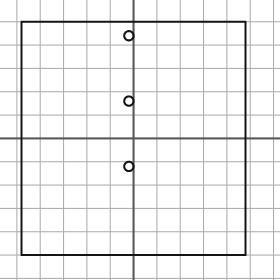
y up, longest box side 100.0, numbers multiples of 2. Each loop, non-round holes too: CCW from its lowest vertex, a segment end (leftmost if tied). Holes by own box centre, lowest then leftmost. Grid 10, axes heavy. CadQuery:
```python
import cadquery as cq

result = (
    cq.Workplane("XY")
    .moveTo(-48.0, -50.0)
    .lineTo(48.0, -50.0)
    .lineTo(48.0, 50.0)
    .lineTo(-48.0, 50.0)
    .close()
    .moveTo(-2.0, -12.0)
    .circle(2.0)
    .moveTo(-2.0, 16.0)
    .circle(2.0)
    .moveTo(-2.0, 44.0)
    .circle(2.0)
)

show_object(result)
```